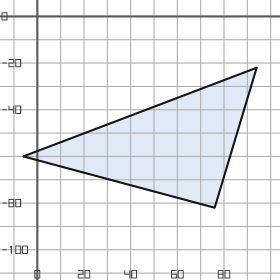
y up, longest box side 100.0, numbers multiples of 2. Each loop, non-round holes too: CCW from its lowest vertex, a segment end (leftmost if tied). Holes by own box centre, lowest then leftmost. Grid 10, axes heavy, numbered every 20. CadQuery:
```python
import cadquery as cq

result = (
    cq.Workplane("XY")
    .moveTo(76.0, -82.0)
    .lineTo(94.0, -22.0)
    .lineTo(-6.0, -60.0)
    .close()
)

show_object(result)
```